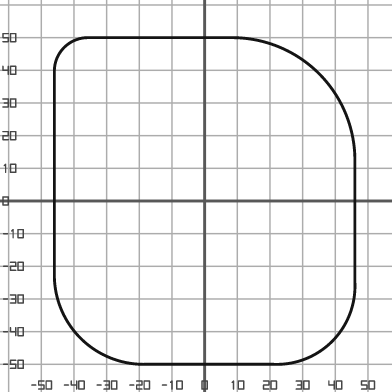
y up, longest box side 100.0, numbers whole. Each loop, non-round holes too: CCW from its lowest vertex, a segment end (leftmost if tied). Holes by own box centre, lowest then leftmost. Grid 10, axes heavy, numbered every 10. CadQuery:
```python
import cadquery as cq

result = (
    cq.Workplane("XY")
    .moveTo(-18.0, -50.0)
    .lineTo(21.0, -50.0)
    .threePointArc((39.0, -43.0), (46.0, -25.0))
    .lineTo(46.0, 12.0)
    .threePointArc((35.0, 39.0), (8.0, 50.0))
    .lineTo(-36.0, 50.0)
    .threePointArc((-43.0, 47.0), (-46.0, 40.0))
    .lineTo(-46.0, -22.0)
    .threePointArc((-38.0, -42.0), (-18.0, -50.0))
    .close()
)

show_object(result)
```